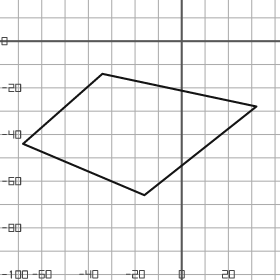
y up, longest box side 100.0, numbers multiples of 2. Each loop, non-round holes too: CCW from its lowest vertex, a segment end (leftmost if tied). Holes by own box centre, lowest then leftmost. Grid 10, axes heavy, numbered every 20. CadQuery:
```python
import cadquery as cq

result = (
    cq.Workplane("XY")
    .moveTo(-16.0, -66.0)
    .lineTo(32.0, -28.0)
    .lineTo(-34.0, -14.0)
    .lineTo(-68.0, -44.0)
    .close()
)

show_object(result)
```